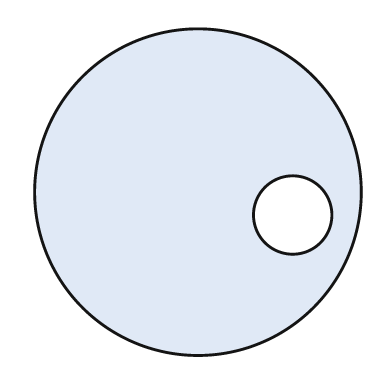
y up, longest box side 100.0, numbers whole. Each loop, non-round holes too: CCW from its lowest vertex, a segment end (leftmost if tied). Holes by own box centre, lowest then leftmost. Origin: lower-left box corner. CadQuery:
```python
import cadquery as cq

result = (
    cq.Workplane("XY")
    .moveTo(50.0, 50.0)
    .circle(50.0)
    .moveTo(79.0, 43.0)
    .circle(12.0)
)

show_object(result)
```